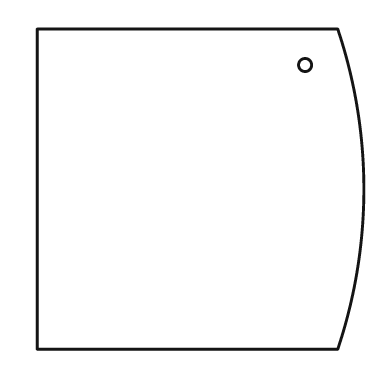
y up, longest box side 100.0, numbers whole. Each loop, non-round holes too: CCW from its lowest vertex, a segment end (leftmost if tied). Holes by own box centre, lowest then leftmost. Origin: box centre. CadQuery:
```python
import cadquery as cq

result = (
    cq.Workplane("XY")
    .moveTo(-50.0, -49.0)
    .lineTo(42.0, -49.0)
    .threePointArc((50.0, 0.0), (42.0, 49.0))
    .lineTo(-50.0, 49.0)
    .close()
    .moveTo(32.0, 38.0)
    .circle(2.0)
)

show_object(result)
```